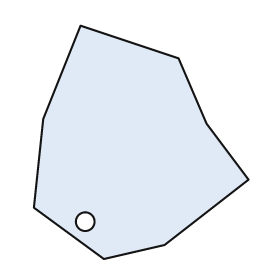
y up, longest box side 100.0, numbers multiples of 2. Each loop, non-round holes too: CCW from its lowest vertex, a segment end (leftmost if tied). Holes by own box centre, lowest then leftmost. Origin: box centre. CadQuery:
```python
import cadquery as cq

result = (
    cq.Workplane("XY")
    .moveTo(-16.0, -50.0)
    .lineTo(10.0, -44.0)
    .lineTo(46.0, -16.0)
    .lineTo(28.0, 8.0)
    .lineTo(16.0, 36.0)
    .lineTo(-26.0, 50.0)
    .lineTo(-42.0, 10.0)
    .lineTo(-46.0, -28.0)
    .close()
    .moveTo(-24.0, -34.0)
    .circle(4.0)
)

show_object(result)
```